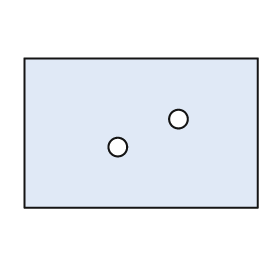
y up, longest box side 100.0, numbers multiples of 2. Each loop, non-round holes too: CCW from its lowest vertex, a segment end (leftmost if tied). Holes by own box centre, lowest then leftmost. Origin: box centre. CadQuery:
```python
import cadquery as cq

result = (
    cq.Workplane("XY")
    .moveTo(-50.0, -32.0)
    .lineTo(50.0, -32.0)
    .lineTo(50.0, 32.0)
    .lineTo(-50.0, 32.0)
    .close()
    .moveTo(-10.0, -6.0)
    .circle(4.0)
    .moveTo(16.0, 6.0)
    .circle(4.0)
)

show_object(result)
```